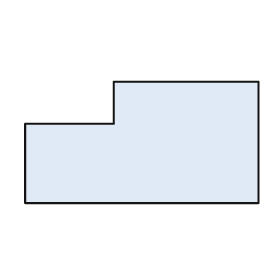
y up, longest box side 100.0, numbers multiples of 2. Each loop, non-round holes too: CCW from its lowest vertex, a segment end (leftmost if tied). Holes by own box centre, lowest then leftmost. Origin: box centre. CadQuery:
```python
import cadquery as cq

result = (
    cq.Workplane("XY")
    .moveTo(-50.0, -26.0)
    .lineTo(50.0, -26.0)
    .lineTo(50.0, 26.0)
    .lineTo(-12.0, 26.0)
    .lineTo(-12.0, 8.0)
    .lineTo(-50.0, 8.0)
    .close()
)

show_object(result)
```